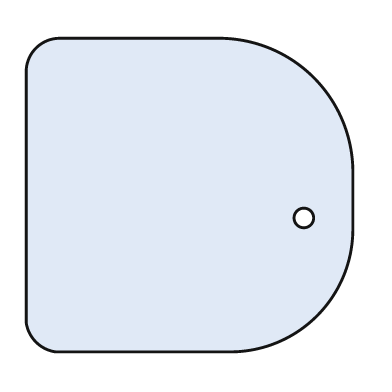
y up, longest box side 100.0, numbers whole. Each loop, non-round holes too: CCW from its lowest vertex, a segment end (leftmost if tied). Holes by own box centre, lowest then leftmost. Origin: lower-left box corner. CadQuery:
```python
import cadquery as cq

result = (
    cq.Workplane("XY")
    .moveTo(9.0, 0.0)
    .lineTo(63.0, 0.0)
    .threePointArc((89.0, 11.0), (100.0, 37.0))
    .lineTo(100.0, 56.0)
    .threePointArc((88.0, 84.0), (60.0, 96.0))
    .lineTo(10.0, 96.0)
    .threePointArc((3.0, 93.0), (0.0, 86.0))
    .lineTo(0.0, 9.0)
    .threePointArc((3.0, 3.0), (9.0, 0.0))
    .close()
    .moveTo(85.0, 41.0)
    .circle(3.0)
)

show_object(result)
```